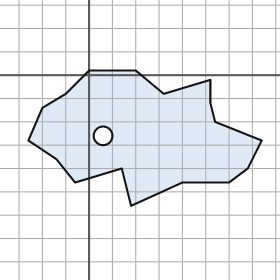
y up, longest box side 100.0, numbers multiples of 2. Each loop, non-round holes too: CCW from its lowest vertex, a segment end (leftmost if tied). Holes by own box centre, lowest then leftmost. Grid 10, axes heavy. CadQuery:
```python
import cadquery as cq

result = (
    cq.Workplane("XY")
    .moveTo(18.0, -56.0)
    .lineTo(40.0, -46.0)
    .lineTo(60.0, -46.0)
    .lineTo(68.0, -40.0)
    .lineTo(74.0, -28.0)
    .lineTo(54.0, -20.0)
    .lineTo(52.0, -12.0)
    .lineTo(52.0, -2.0)
    .lineTo(32.0, -8.0)
    .lineTo(20.0, 2.0)
    .lineTo(0.0, 2.0)
    .lineTo(-10.0, -8.0)
    .lineTo(-20.0, -14.0)
    .lineTo(-26.0, -28.0)
    .lineTo(-14.0, -36.0)
    .lineTo(-6.0, -46.0)
    .lineTo(14.0, -40.0)
    .close()
    .moveTo(6.0, -26.0)
    .circle(4.0)
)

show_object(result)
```